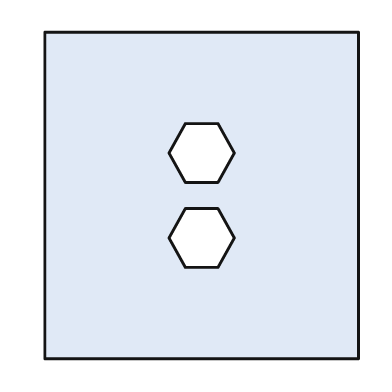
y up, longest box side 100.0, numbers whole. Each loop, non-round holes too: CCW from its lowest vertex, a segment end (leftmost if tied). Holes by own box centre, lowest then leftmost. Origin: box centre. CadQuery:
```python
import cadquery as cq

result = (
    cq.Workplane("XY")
    .moveTo(-48.0, -50.0)
    .lineTo(48.0, -50.0)
    .lineTo(48.0, 50.0)
    .lineTo(-48.0, 50.0)
    .close()
    .moveTo(-5.0, -22.0)
    .lineTo(5.0, -22.0)
    .lineTo(10.0, -13.0)
    .lineTo(5.0, -4.0)
    .lineTo(-5.0, -4.0)
    .lineTo(-10.0, -13.0)
    .close()
    .moveTo(-5.0, 4.0)
    .lineTo(5.0, 4.0)
    .lineTo(10.0, 13.0)
    .lineTo(5.0, 22.0)
    .lineTo(-5.0, 22.0)
    .lineTo(-10.0, 13.0)
    .close()
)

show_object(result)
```